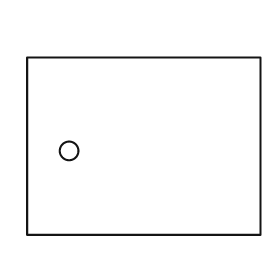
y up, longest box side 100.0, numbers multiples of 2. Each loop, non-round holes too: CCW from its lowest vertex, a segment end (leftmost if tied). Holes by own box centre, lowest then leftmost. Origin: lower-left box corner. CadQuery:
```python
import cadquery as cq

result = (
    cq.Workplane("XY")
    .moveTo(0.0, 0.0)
    .lineTo(100.0, 0.0)
    .lineTo(100.0, 76.0)
    .lineTo(0.0, 76.0)
    .close()
    .moveTo(18.0, 36.0)
    .circle(4.0)
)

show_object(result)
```